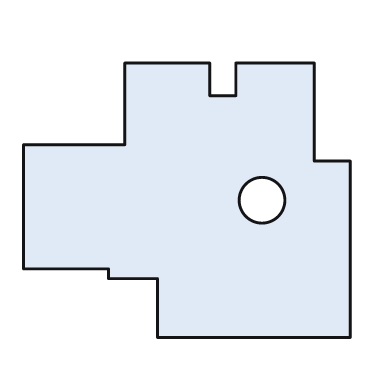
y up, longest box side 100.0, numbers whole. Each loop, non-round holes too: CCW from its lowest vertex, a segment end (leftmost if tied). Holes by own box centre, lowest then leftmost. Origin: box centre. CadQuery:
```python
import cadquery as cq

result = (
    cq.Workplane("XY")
    .moveTo(-9.0, -42.0)
    .lineTo(50.0, -42.0)
    .lineTo(50.0, 12.0)
    .lineTo(39.0, 12.0)
    .lineTo(39.0, 42.0)
    .lineTo(15.0, 42.0)
    .lineTo(15.0, 32.0)
    .lineTo(7.0, 32.0)
    .lineTo(7.0, 42.0)
    .lineTo(-19.0, 42.0)
    .lineTo(-19.0, 17.0)
    .lineTo(-50.0, 17.0)
    .lineTo(-50.0, -21.0)
    .lineTo(-24.0, -21.0)
    .lineTo(-24.0, -24.0)
    .lineTo(-9.0, -24.0)
    .close()
    .moveTo(23.0, 0.0)
    .circle(7.0)
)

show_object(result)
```